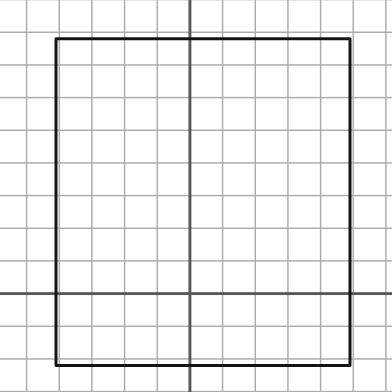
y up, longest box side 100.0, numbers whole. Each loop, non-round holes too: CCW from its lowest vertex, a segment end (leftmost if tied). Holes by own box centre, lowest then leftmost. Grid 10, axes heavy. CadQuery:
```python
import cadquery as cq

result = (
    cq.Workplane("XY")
    .moveTo(-41.0, -22.0)
    .lineTo(49.0, -22.0)
    .lineTo(49.0, 78.0)
    .lineTo(-41.0, 78.0)
    .close()
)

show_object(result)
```